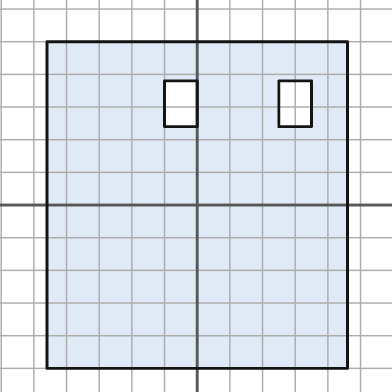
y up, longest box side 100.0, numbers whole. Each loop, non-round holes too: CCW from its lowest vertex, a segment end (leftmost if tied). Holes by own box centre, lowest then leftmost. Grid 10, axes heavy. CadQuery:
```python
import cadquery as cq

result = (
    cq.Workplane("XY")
    .moveTo(-46.0, -50.0)
    .lineTo(46.0, -50.0)
    .lineTo(46.0, 50.0)
    .lineTo(-46.0, 50.0)
    .close()
    .moveTo(-10.0, 24.0)
    .lineTo(0.0, 24.0)
    .lineTo(0.0, 38.0)
    .lineTo(-10.0, 38.0)
    .close()
    .moveTo(25.0, 24.0)
    .lineTo(35.0, 24.0)
    .lineTo(35.0, 38.0)
    .lineTo(25.0, 38.0)
    .close()
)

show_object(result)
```